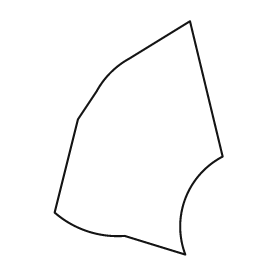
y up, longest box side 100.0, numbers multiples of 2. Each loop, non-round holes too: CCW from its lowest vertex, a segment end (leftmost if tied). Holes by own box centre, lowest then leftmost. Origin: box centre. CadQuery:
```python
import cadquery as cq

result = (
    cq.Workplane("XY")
    .moveTo(20.0, -50.0)
    .threePointArc((20.0, -26.0), (36.0, -8.0))
    .lineTo(22.0, 50.0)
    .lineTo(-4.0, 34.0)
    .threePointArc((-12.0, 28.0), (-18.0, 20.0))
    .lineTo(-26.0, 8.0)
    .lineTo(-36.0, -32.0)
    .threePointArc((-22.0, -40.0), (-6.0, -42.0))
    .close()
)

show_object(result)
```